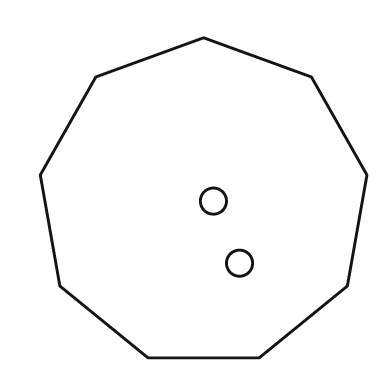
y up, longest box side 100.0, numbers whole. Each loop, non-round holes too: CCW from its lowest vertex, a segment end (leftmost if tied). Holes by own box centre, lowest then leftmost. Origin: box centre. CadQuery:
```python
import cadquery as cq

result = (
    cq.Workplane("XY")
    .moveTo(-17.0, -49.0)
    .lineTo(17.0, -49.0)
    .lineTo(44.0, -27.0)
    .lineTo(50.0, 7.0)
    .lineTo(33.0, 37.0)
    .lineTo(0.0, 49.0)
    .lineTo(-33.0, 37.0)
    .lineTo(-50.0, 7.0)
    .lineTo(-44.0, -27.0)
    .close()
    .moveTo(11.0, -20.0)
    .circle(4.0)
    .moveTo(3.0, -1.0)
    .circle(4.0)
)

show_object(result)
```